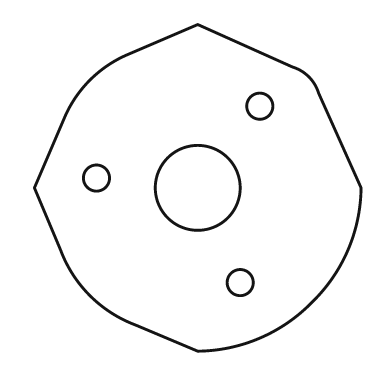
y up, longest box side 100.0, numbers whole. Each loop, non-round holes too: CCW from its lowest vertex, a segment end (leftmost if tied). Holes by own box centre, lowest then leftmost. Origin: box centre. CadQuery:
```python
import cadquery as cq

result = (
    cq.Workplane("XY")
    .moveTo(0.0, -50.0)
    .threePointArc((19.0, -46.0), (35.0, -35.0))
    .threePointArc((46.0, -19.0), (50.0, 0.0))
    .lineTo(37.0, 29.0)
    .threePointArc((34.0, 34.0), (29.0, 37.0))
    .lineTo(0.0, 50.0)
    .lineTo(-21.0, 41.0)
    .threePointArc((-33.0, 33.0), (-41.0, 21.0))
    .lineTo(-50.0, 0.0)
    .lineTo(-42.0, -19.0)
    .threePointArc((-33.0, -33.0), (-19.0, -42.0))
    .close()
    .moveTo(13.0, -29.0)
    .circle(4.0)
    .moveTo(0.0, 0.0)
    .circle(13.0)
    .moveTo(-31.0, 3.0)
    .circle(4.0)
    .moveTo(19.0, 25.0)
    .circle(4.0)
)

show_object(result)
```